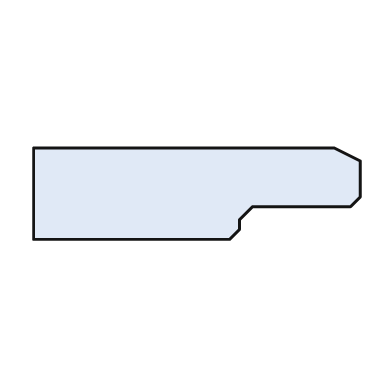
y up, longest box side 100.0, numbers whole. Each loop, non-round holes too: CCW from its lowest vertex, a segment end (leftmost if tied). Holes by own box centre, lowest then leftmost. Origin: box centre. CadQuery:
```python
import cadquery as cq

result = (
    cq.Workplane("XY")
    .moveTo(-50.0, -14.0)
    .lineTo(10.0, -14.0)
    .lineTo(13.0, -11.0)
    .lineTo(13.0, -8.0)
    .lineTo(17.0, -4.0)
    .lineTo(47.0, -4.0)
    .lineTo(50.0, -1.0)
    .lineTo(50.0, 10.0)
    .lineTo(42.0, 14.0)
    .lineTo(-50.0, 14.0)
    .close()
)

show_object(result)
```